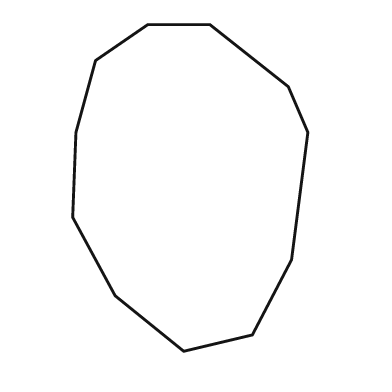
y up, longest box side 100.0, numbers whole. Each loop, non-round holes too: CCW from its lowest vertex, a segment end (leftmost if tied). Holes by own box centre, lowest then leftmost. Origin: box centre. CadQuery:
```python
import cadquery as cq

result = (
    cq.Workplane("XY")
    .moveTo(-2.0, -50.0)
    .lineTo(19.0, -45.0)
    .lineTo(31.0, -22.0)
    .lineTo(36.0, 17.0)
    .lineTo(30.0, 31.0)
    .lineTo(6.0, 50.0)
    .lineTo(-13.0, 50.0)
    .lineTo(-29.0, 39.0)
    .lineTo(-35.0, 17.0)
    .lineTo(-36.0, -9.0)
    .lineTo(-23.0, -33.0)
    .close()
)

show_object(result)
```